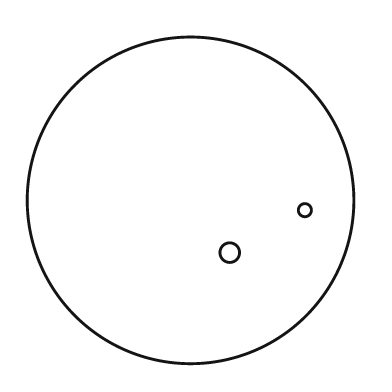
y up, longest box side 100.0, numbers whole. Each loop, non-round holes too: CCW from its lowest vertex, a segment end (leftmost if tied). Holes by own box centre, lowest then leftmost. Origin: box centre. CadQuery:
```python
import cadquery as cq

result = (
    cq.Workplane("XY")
    .moveTo(0.0, 0.0)
    .circle(50.0)
    .moveTo(12.0, -16.0)
    .circle(3.0)
    .moveTo(35.0, -3.0)
    .circle(2.0)
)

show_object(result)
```